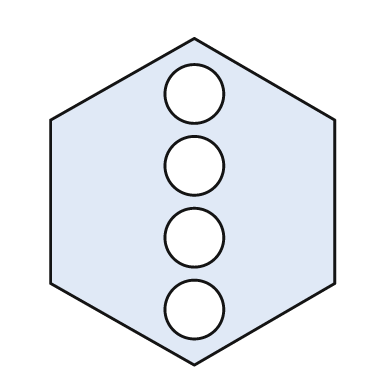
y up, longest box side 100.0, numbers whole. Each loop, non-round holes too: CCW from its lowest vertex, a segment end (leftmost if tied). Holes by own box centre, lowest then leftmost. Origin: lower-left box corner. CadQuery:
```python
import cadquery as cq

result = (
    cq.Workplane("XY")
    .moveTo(44.0, 0.0)
    .lineTo(87.0, 25.0)
    .lineTo(87.0, 75.0)
    .lineTo(44.0, 100.0)
    .lineTo(0.0, 75.0)
    .lineTo(0.0, 25.0)
    .close()
    .moveTo(44.0, 17.0)
    .circle(9.0)
    .moveTo(44.0, 39.0)
    .circle(9.0)
    .moveTo(44.0, 61.0)
    .circle(9.0)
    .moveTo(44.0, 83.0)
    .circle(9.0)
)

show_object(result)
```